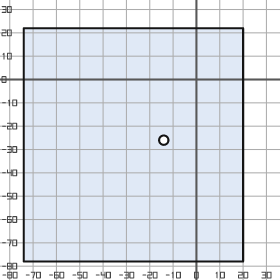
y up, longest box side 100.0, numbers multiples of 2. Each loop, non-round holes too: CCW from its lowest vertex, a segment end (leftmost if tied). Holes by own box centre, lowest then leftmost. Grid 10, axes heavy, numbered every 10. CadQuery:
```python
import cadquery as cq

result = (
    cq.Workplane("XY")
    .moveTo(-74.0, -78.0)
    .lineTo(20.0, -78.0)
    .lineTo(20.0, 22.0)
    .lineTo(-74.0, 22.0)
    .close()
    .moveTo(-14.0, -26.0)
    .circle(2.0)
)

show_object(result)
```